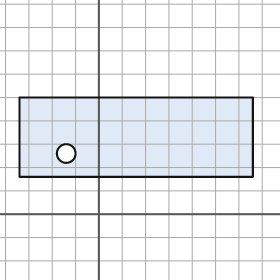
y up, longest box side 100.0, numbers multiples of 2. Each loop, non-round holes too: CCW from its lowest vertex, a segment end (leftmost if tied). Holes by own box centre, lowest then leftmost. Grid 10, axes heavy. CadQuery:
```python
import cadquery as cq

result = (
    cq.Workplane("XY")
    .moveTo(-34.0, 16.0)
    .lineTo(66.0, 16.0)
    .lineTo(66.0, 50.0)
    .lineTo(-34.0, 50.0)
    .close()
    .moveTo(-14.0, 26.0)
    .circle(4.0)
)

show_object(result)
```